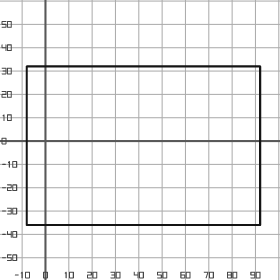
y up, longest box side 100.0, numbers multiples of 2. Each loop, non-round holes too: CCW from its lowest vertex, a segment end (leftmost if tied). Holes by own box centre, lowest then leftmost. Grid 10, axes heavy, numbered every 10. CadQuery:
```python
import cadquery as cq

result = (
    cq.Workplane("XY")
    .moveTo(-8.0, -36.0)
    .lineTo(92.0, -36.0)
    .lineTo(92.0, 32.0)
    .lineTo(-8.0, 32.0)
    .close()
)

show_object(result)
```